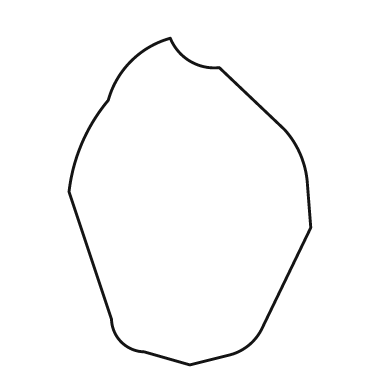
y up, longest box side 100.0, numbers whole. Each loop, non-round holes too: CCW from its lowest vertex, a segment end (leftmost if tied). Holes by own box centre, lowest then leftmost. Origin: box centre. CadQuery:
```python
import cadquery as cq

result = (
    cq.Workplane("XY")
    .moveTo(0.0, -50.0)
    .lineTo(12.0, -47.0)
    .threePointArc((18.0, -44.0), (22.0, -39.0))
    .lineTo(37.0, -8.0)
    .lineTo(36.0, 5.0)
    .threePointArc((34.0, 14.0), (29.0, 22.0))
    .lineTo(9.0, 41.0)
    .threePointArc((0.0, 43.0), (-6.0, 50.0))
    .threePointArc((-18.0, 43.0), (-25.0, 31.0))
    .threePointArc((-33.0, 18.0), (-37.0, 3.0))
    .lineTo(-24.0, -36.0)
    .threePointArc((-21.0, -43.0), (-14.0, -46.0))
    .close()
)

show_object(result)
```